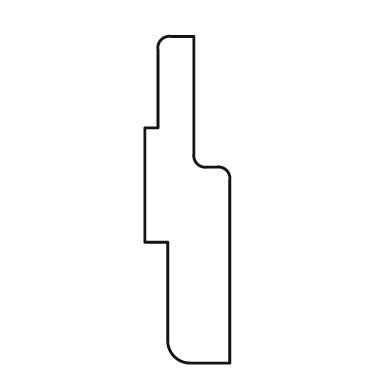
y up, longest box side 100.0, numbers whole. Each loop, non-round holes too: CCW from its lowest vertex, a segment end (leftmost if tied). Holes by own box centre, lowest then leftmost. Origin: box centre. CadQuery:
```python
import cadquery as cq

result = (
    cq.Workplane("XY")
    .moveTo(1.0, -50.0)
    .lineTo(13.0, -50.0)
    .lineTo(13.0, 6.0)
    .threePointArc((12.0, 9.0), (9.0, 10.0))
    .lineTo(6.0, 10.0)
    .threePointArc((3.0, 11.0), (2.0, 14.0))
    .lineTo(2.0, 50.0)
    .lineTo(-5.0, 50.0)
    .threePointArc((-8.0, 49.0), (-9.0, 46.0))
    .lineTo(-9.0, 22.0)
    .lineTo(-13.0, 22.0)
    .lineTo(-13.0, -13.0)
    .lineTo(-6.0, -13.0)
    .lineTo(-6.0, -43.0)
    .threePointArc((-4.0, -48.0), (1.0, -50.0))
    .close()
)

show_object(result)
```